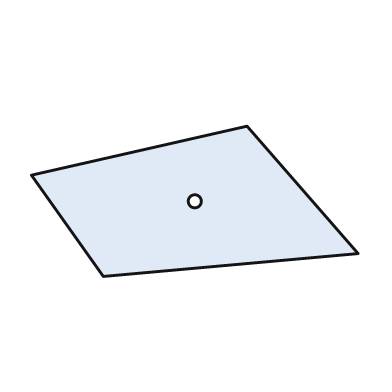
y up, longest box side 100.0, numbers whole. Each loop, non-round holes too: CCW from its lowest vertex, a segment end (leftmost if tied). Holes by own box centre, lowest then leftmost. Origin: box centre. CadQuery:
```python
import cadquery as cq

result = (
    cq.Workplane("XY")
    .moveTo(-28.0, -23.0)
    .lineTo(50.0, -16.0)
    .lineTo(16.0, 23.0)
    .lineTo(-50.0, 8.0)
    .close()
    .moveTo(0.0, 0.0)
    .circle(2.0)
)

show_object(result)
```